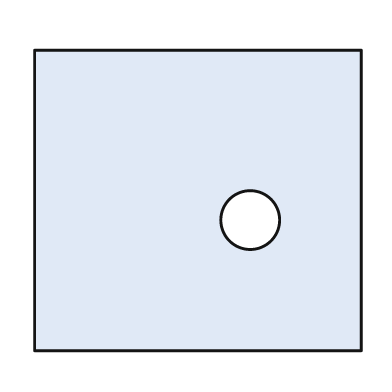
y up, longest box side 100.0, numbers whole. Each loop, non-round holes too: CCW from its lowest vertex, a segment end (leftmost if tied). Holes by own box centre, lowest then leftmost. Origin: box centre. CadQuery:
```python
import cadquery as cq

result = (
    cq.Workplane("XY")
    .moveTo(-50.0, -46.0)
    .lineTo(50.0, -46.0)
    .lineTo(50.0, 46.0)
    .lineTo(-50.0, 46.0)
    .close()
    .moveTo(16.0, -6.0)
    .circle(9.0)
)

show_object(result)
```